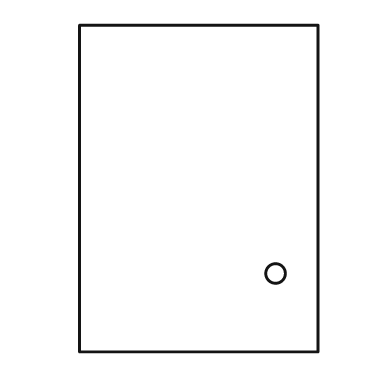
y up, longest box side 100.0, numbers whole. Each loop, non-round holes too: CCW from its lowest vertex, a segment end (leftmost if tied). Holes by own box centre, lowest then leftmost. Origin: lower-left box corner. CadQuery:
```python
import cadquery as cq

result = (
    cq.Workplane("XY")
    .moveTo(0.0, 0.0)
    .lineTo(73.0, 0.0)
    .lineTo(73.0, 100.0)
    .lineTo(0.0, 100.0)
    .close()
    .moveTo(60.0, 24.0)
    .circle(3.0)
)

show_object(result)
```